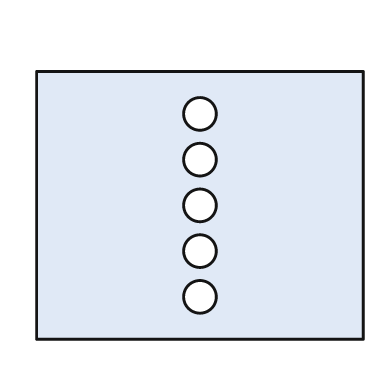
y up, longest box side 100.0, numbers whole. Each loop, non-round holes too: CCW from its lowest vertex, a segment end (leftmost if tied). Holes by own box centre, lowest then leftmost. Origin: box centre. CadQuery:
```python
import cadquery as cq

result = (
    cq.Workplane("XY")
    .moveTo(-50.0, -41.0)
    .lineTo(50.0, -41.0)
    .lineTo(50.0, 41.0)
    .lineTo(-50.0, 41.0)
    .close()
    .moveTo(0.0, -28.0)
    .circle(5.0)
    .moveTo(0.0, -14.0)
    .circle(5.0)
    .moveTo(0.0, 0.0)
    .circle(5.0)
    .moveTo(0.0, 14.0)
    .circle(5.0)
    .moveTo(0.0, 28.0)
    .circle(5.0)
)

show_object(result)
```